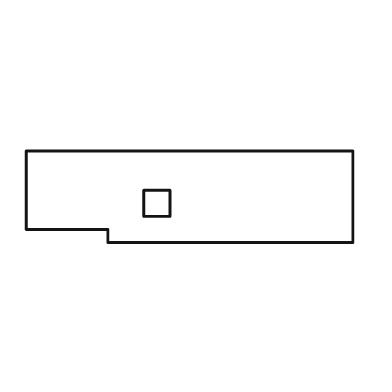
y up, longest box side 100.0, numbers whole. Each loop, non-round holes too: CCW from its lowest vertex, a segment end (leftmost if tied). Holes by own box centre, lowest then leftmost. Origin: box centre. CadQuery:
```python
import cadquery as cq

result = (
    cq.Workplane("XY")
    .moveTo(-25.0, -14.0)
    .lineTo(50.0, -14.0)
    .lineTo(50.0, 14.0)
    .lineTo(-50.0, 14.0)
    .lineTo(-50.0, -10.0)
    .lineTo(-25.0, -10.0)
    .close()
    .moveTo(-14.0, -6.0)
    .lineTo(-6.0, -6.0)
    .lineTo(-6.0, 2.0)
    .lineTo(-14.0, 2.0)
    .close()
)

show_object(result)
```